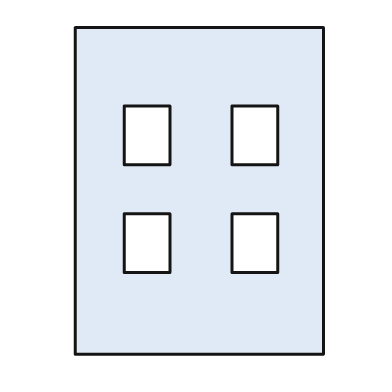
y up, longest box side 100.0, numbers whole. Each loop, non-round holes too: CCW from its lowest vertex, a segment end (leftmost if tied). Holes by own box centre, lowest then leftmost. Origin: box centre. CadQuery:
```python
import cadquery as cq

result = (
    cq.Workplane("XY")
    .moveTo(-38.0, -50.0)
    .lineTo(38.0, -50.0)
    .lineTo(38.0, 50.0)
    .lineTo(-38.0, 50.0)
    .close()
    .moveTo(-23.0, -25.0)
    .lineTo(-9.0, -25.0)
    .lineTo(-9.0, -7.0)
    .lineTo(-23.0, -7.0)
    .close()
    .moveTo(10.0, -25.0)
    .lineTo(24.0, -25.0)
    .lineTo(24.0, -7.0)
    .lineTo(10.0, -7.0)
    .close()
    .moveTo(-23.0, 8.0)
    .lineTo(-9.0, 8.0)
    .lineTo(-9.0, 26.0)
    .lineTo(-23.0, 26.0)
    .close()
    .moveTo(10.0, 8.0)
    .lineTo(24.0, 8.0)
    .lineTo(24.0, 26.0)
    .lineTo(10.0, 26.0)
    .close()
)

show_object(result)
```